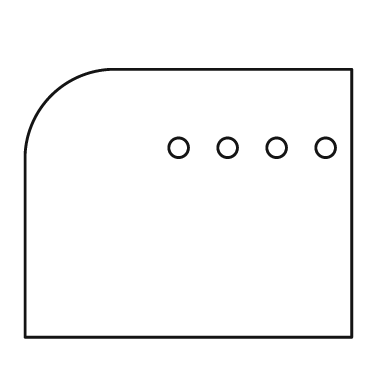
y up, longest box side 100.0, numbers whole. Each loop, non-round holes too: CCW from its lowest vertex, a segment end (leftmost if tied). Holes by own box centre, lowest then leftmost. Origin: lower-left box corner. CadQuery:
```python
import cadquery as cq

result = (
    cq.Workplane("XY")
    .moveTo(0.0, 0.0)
    .lineTo(100.0, 0.0)
    .lineTo(100.0, 82.0)
    .lineTo(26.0, 82.0)
    .threePointArc((8.0, 74.0), (0.0, 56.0))
    .close()
    .moveTo(47.0, 58.0)
    .circle(3.0)
    .moveTo(62.0, 58.0)
    .circle(3.0)
    .moveTo(77.0, 58.0)
    .circle(3.0)
    .moveTo(92.0, 58.0)
    .circle(3.0)
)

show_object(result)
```